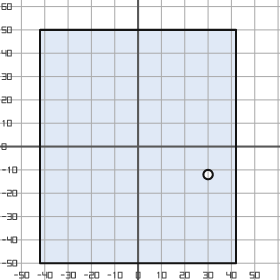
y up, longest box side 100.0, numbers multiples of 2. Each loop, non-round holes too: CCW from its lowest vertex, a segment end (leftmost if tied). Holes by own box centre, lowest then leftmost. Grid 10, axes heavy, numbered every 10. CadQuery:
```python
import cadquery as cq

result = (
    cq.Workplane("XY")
    .moveTo(-42.0, -50.0)
    .lineTo(42.0, -50.0)
    .lineTo(42.0, 50.0)
    .lineTo(-42.0, 50.0)
    .close()
    .moveTo(30.0, -12.0)
    .circle(2.0)
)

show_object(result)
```